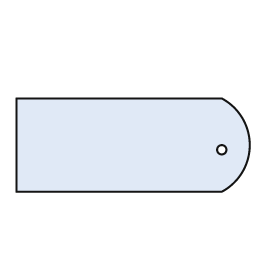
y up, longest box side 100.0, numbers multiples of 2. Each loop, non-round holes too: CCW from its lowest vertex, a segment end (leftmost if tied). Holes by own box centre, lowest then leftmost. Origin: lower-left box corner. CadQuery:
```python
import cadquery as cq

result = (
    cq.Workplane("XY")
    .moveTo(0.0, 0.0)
    .lineTo(88.0, 0.0)
    .threePointArc((100.0, 20.0), (88.0, 40.0))
    .lineTo(0.0, 40.0)
    .close()
    .moveTo(88.0, 18.0)
    .circle(2.0)
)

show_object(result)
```